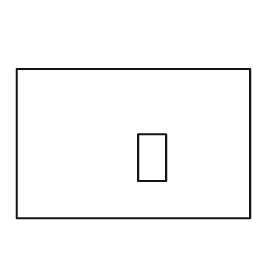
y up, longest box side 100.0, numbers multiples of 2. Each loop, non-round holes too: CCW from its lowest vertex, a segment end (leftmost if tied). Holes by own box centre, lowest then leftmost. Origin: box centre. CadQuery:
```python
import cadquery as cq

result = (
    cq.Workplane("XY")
    .moveTo(-50.0, -32.0)
    .lineTo(50.0, -32.0)
    .lineTo(50.0, 32.0)
    .lineTo(-50.0, 32.0)
    .close()
    .moveTo(2.0, -16.0)
    .lineTo(14.0, -16.0)
    .lineTo(14.0, 4.0)
    .lineTo(2.0, 4.0)
    .close()
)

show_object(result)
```